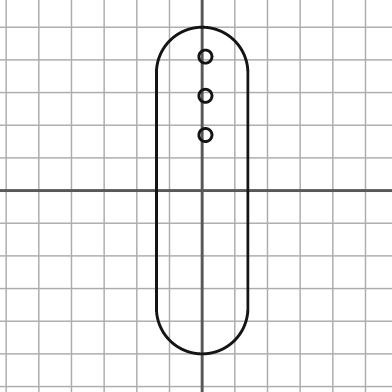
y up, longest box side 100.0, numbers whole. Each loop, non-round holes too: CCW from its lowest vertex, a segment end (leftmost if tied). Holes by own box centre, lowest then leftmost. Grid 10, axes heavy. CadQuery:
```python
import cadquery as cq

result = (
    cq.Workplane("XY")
    .moveTo(-14.0, -36.0)
    .threePointArc((0.0, -50.0), (14.0, -36.0))
    .lineTo(14.0, 36.0)
    .threePointArc((0.0, 50.0), (-14.0, 36.0))
    .close()
    .moveTo(1.0, 17.0)
    .circle(2.0)
    .moveTo(1.0, 29.0)
    .circle(2.0)
    .moveTo(1.0, 41.0)
    .circle(2.0)
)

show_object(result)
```